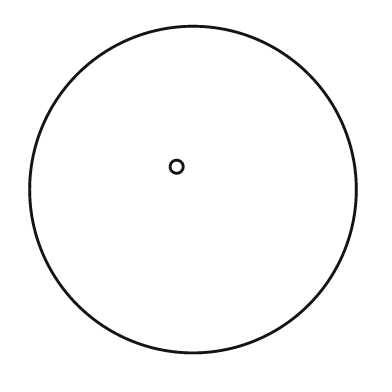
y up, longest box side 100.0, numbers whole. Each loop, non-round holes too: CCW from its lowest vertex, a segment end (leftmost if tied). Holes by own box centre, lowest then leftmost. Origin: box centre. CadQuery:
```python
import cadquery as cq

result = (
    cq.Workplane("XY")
    .moveTo(0.0, 0.0)
    .circle(50.0)
    .moveTo(-5.0, 7.0)
    .circle(2.0)
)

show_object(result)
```